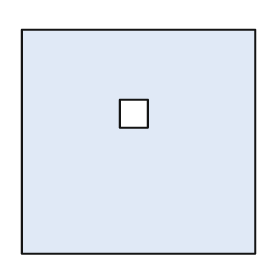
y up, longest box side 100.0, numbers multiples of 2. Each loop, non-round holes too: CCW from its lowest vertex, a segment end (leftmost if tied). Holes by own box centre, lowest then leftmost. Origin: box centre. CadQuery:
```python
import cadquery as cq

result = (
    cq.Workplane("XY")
    .moveTo(-50.0, -48.0)
    .lineTo(50.0, -48.0)
    .lineTo(50.0, 48.0)
    .lineTo(-50.0, 48.0)
    .close()
    .moveTo(-8.0, 6.0)
    .lineTo(4.0, 6.0)
    .lineTo(4.0, 18.0)
    .lineTo(-8.0, 18.0)
    .close()
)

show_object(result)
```